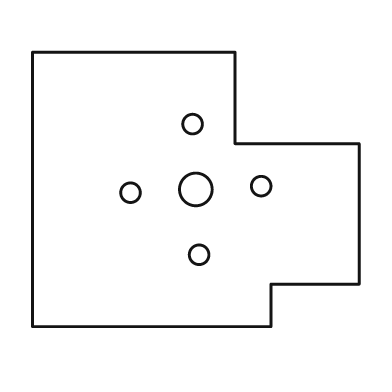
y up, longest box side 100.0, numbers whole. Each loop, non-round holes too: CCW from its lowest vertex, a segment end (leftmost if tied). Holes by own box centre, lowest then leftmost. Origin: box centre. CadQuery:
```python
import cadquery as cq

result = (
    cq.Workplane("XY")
    .moveTo(-50.0, -42.0)
    .lineTo(23.0, -42.0)
    .lineTo(23.0, -29.0)
    .lineTo(50.0, -29.0)
    .lineTo(50.0, 14.0)
    .lineTo(12.0, 14.0)
    .lineTo(12.0, 42.0)
    .lineTo(-50.0, 42.0)
    .close()
    .moveTo(1.0, -20.0)
    .circle(3.0)
    .moveTo(-20.0, -1.0)
    .circle(3.0)
    .moveTo(0.0, 0.0)
    .circle(5.0)
    .moveTo(20.0, 1.0)
    .circle(3.0)
    .moveTo(-1.0, 20.0)
    .circle(3.0)
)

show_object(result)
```